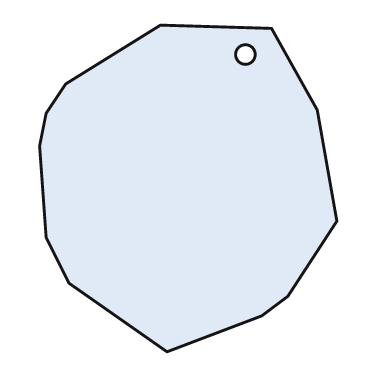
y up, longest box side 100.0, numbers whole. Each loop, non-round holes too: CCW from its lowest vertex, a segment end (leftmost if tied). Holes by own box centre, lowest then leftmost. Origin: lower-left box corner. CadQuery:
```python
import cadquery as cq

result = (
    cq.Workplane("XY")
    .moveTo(39.0, 0.0)
    .lineTo(68.0, 11.0)
    .lineTo(76.0, 17.0)
    .lineTo(91.0, 40.0)
    .lineTo(85.0, 74.0)
    .lineTo(71.0, 99.0)
    .lineTo(37.0, 100.0)
    .lineTo(8.0, 82.0)
    .lineTo(2.0, 73.0)
    .lineTo(0.0, 63.0)
    .lineTo(2.0, 35.0)
    .lineTo(9.0, 21.0)
    .close()
    .moveTo(63.0, 91.0)
    .circle(3.0)
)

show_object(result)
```